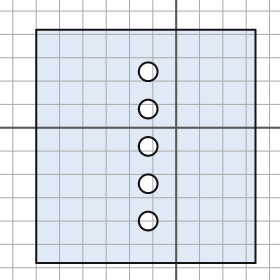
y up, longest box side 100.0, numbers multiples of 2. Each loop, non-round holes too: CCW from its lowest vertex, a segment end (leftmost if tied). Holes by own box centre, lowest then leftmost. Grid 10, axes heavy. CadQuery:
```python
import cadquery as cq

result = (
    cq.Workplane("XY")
    .moveTo(-60.0, -58.0)
    .lineTo(34.0, -58.0)
    .lineTo(34.0, 42.0)
    .lineTo(-60.0, 42.0)
    .close()
    .moveTo(-12.0, -40.0)
    .circle(4.0)
    .moveTo(-12.0, -24.0)
    .circle(4.0)
    .moveTo(-12.0, -8.0)
    .circle(4.0)
    .moveTo(-12.0, 8.0)
    .circle(4.0)
    .moveTo(-12.0, 24.0)
    .circle(4.0)
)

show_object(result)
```